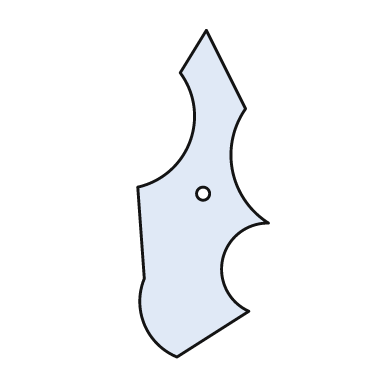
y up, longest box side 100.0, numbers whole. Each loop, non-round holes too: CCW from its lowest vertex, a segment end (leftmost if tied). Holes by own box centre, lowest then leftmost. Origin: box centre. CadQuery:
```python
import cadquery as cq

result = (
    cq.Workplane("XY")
    .moveTo(-8.0, -50.0)
    .lineTo(14.0, -36.0)
    .threePointArc((6.0, -20.0), (20.0, -9.0))
    .threePointArc((9.0, 7.0), (13.0, 26.0))
    .lineTo(1.0, 50.0)
    .lineTo(-7.0, 37.0)
    .threePointArc((-4.0, 16.0), (-20.0, 2.0))
    .lineTo(-18.0, -26.0)
    .threePointArc((-18.0, -40.0), (-8.0, -50.0))
    .close()
    .moveTo(0.0, 0.0)
    .circle(2.0)
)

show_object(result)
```